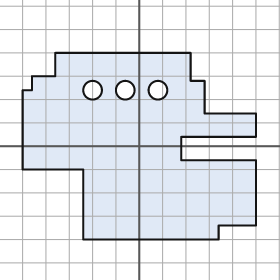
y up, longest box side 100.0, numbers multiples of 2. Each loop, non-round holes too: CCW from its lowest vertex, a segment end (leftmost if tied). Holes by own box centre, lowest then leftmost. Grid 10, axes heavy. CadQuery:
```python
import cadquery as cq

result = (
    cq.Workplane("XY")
    .moveTo(-24.0, -40.0)
    .lineTo(34.0, -40.0)
    .lineTo(34.0, -34.0)
    .lineTo(50.0, -34.0)
    .lineTo(50.0, -6.0)
    .lineTo(18.0, -6.0)
    .lineTo(18.0, 4.0)
    .lineTo(50.0, 4.0)
    .lineTo(50.0, 14.0)
    .lineTo(28.0, 14.0)
    .lineTo(28.0, 28.0)
    .lineTo(22.0, 28.0)
    .lineTo(22.0, 40.0)
    .lineTo(-36.0, 40.0)
    .lineTo(-36.0, 30.0)
    .lineTo(-46.0, 30.0)
    .lineTo(-46.0, 24.0)
    .lineTo(-50.0, 24.0)
    .lineTo(-50.0, -10.0)
    .lineTo(-24.0, -10.0)
    .close()
    .moveTo(-20.0, 24.0)
    .circle(4.0)
    .moveTo(-6.0, 24.0)
    .circle(4.0)
    .moveTo(8.0, 24.0)
    .circle(4.0)
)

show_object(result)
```